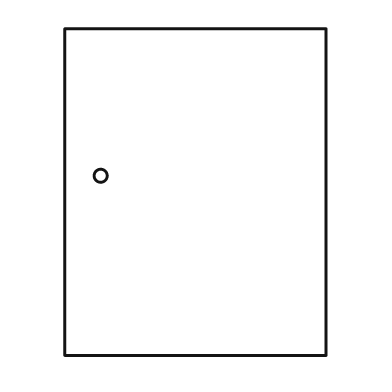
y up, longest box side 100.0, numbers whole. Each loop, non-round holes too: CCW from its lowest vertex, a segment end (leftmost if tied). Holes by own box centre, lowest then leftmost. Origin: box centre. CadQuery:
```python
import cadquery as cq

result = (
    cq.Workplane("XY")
    .moveTo(-40.0, -50.0)
    .lineTo(40.0, -50.0)
    .lineTo(40.0, 50.0)
    .lineTo(-40.0, 50.0)
    .close()
    .moveTo(-29.0, 5.0)
    .circle(2.0)
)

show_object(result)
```